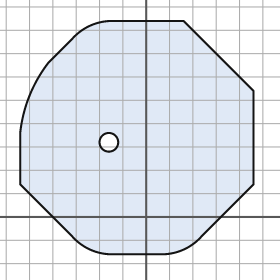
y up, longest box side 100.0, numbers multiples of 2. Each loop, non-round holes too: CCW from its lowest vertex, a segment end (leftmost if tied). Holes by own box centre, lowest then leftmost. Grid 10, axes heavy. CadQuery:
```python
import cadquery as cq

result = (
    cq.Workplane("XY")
    .moveTo(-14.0, -16.0)
    .lineTo(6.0, -16.0)
    .threePointArc((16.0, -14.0), (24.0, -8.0))
    .lineTo(46.0, 14.0)
    .lineTo(46.0, 54.0)
    .lineTo(16.0, 84.0)
    .lineTo(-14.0, 84.0)
    .threePointArc((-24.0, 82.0), (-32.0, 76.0))
    .lineTo(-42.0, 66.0)
    .threePointArc((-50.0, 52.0), (-54.0, 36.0))
    .lineTo(-54.0, 14.0)
    .lineTo(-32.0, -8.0)
    .threePointArc((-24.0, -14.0), (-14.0, -16.0))
    .close()
    .moveTo(-16.0, 32.0)
    .circle(4.0)
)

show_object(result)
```